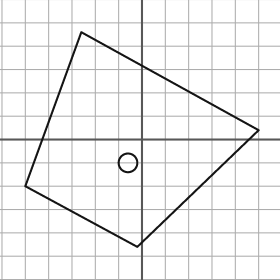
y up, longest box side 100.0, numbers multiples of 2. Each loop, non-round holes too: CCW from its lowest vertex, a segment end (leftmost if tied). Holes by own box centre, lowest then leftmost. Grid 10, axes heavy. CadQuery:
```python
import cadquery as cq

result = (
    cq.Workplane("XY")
    .moveTo(-2.0, -46.0)
    .lineTo(50.0, 4.0)
    .lineTo(-26.0, 46.0)
    .lineTo(-50.0, -20.0)
    .close()
    .moveTo(-6.0, -10.0)
    .circle(4.0)
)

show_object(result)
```